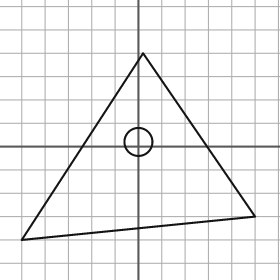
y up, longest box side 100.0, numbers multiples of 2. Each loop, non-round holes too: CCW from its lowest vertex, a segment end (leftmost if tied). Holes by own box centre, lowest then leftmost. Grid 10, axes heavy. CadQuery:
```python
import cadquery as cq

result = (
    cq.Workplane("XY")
    .moveTo(-50.0, -40.0)
    .lineTo(50.0, -30.0)
    .lineTo(2.0, 40.0)
    .close()
    .moveTo(0.0, 2.0)
    .circle(6.0)
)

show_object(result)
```